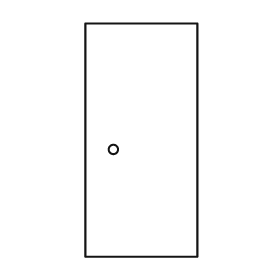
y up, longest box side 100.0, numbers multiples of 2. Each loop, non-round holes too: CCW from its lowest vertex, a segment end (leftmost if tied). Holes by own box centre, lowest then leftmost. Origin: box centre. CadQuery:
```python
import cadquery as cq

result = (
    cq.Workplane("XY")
    .moveTo(-24.0, -50.0)
    .lineTo(24.0, -50.0)
    .lineTo(24.0, 50.0)
    .lineTo(-24.0, 50.0)
    .close()
    .moveTo(-12.0, -4.0)
    .circle(2.0)
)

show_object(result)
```